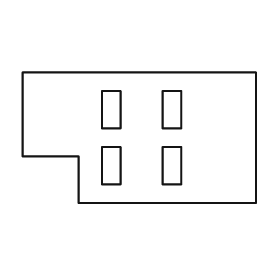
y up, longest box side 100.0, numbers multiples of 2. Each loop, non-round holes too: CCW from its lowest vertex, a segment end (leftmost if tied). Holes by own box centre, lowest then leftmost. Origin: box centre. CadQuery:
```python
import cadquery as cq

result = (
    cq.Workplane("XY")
    .moveTo(-26.0, -28.0)
    .lineTo(50.0, -28.0)
    .lineTo(50.0, 28.0)
    .lineTo(-50.0, 28.0)
    .lineTo(-50.0, -8.0)
    .lineTo(-26.0, -8.0)
    .close()
    .moveTo(-16.0, -20.0)
    .lineTo(-8.0, -20.0)
    .lineTo(-8.0, -4.0)
    .lineTo(-16.0, -4.0)
    .close()
    .moveTo(10.0, -20.0)
    .lineTo(18.0, -20.0)
    .lineTo(18.0, -4.0)
    .lineTo(10.0, -4.0)
    .close()
    .moveTo(-16.0, 4.0)
    .lineTo(-8.0, 4.0)
    .lineTo(-8.0, 20.0)
    .lineTo(-16.0, 20.0)
    .close()
    .moveTo(10.0, 4.0)
    .lineTo(18.0, 4.0)
    .lineTo(18.0, 20.0)
    .lineTo(10.0, 20.0)
    .close()
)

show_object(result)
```